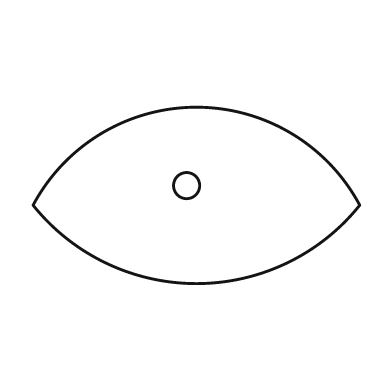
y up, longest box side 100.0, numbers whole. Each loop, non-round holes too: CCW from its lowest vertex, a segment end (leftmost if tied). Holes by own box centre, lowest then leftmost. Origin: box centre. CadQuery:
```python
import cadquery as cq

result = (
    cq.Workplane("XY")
    .moveTo(-50.0, -3.0)
    .threePointArc((0.0, -27.0), (50.0, -3.0))
    .threePointArc((0.0, 27.0), (-50.0, -3.0))
    .close()
    .moveTo(-3.0, 3.0)
    .circle(4.0)
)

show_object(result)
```